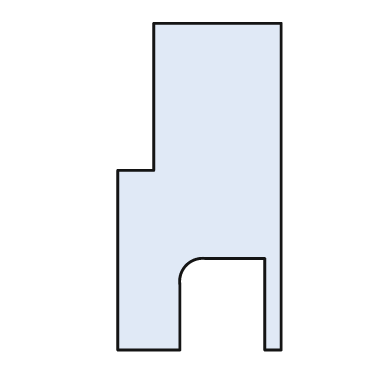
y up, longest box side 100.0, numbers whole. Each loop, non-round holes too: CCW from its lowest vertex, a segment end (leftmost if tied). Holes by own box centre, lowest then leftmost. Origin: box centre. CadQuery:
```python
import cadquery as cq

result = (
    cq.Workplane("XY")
    .moveTo(-25.0, -50.0)
    .lineTo(-6.0, -50.0)
    .lineTo(-6.0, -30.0)
    .threePointArc((-4.0, -24.0), (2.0, -22.0))
    .lineTo(20.0, -22.0)
    .lineTo(20.0, -50.0)
    .lineTo(25.0, -50.0)
    .lineTo(25.0, 50.0)
    .lineTo(-14.0, 50.0)
    .lineTo(-14.0, 5.0)
    .lineTo(-25.0, 5.0)
    .close()
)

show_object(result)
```